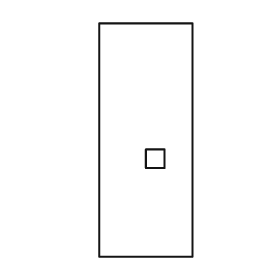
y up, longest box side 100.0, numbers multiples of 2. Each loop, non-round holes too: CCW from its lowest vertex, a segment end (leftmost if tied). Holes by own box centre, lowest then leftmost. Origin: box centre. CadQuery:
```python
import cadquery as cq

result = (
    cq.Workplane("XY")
    .moveTo(-20.0, -50.0)
    .lineTo(20.0, -50.0)
    .lineTo(20.0, 50.0)
    .lineTo(-20.0, 50.0)
    .close()
    .moveTo(0.0, -12.0)
    .lineTo(8.0, -12.0)
    .lineTo(8.0, -4.0)
    .lineTo(0.0, -4.0)
    .close()
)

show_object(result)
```